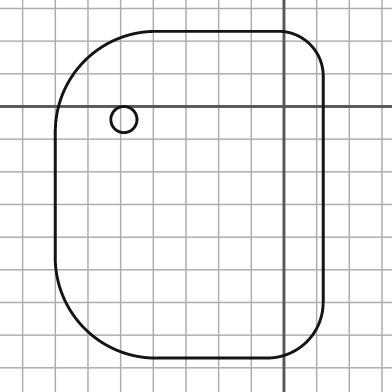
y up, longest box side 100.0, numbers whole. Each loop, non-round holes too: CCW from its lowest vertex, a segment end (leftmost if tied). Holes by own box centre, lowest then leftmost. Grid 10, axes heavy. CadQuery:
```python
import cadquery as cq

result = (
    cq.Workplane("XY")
    .moveTo(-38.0, -77.0)
    .lineTo(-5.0, -77.0)
    .threePointArc((7.0, -72.0), (12.0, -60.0))
    .lineTo(12.0, 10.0)
    .threePointArc((8.0, 19.0), (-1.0, 23.0))
    .lineTo(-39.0, 23.0)
    .threePointArc((-61.0, 14.0), (-70.0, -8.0))
    .lineTo(-70.0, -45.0)
    .threePointArc((-61.0, -68.0), (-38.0, -77.0))
    .close()
    .moveTo(-49.0, -4.0)
    .circle(4.0)
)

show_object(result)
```